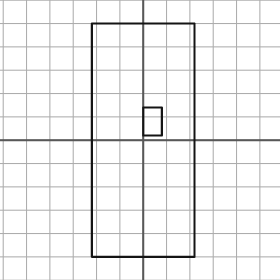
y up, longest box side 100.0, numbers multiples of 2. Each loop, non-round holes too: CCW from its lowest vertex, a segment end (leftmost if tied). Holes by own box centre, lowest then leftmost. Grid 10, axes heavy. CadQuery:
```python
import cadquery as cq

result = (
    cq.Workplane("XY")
    .moveTo(-22.0, -50.0)
    .lineTo(22.0, -50.0)
    .lineTo(22.0, 50.0)
    .lineTo(-22.0, 50.0)
    .close()
    .moveTo(0.0, 2.0)
    .lineTo(8.0, 2.0)
    .lineTo(8.0, 14.0)
    .lineTo(0.0, 14.0)
    .close()
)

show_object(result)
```